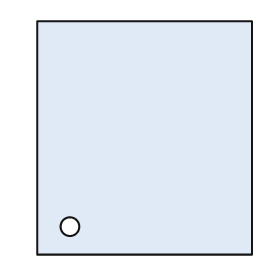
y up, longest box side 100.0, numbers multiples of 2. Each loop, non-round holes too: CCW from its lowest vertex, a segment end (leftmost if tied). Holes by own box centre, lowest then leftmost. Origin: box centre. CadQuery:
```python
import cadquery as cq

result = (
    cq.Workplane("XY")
    .moveTo(-46.0, -50.0)
    .lineTo(46.0, -50.0)
    .lineTo(46.0, 50.0)
    .lineTo(-46.0, 50.0)
    .close()
    .moveTo(-32.0, -38.0)
    .circle(4.0)
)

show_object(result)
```